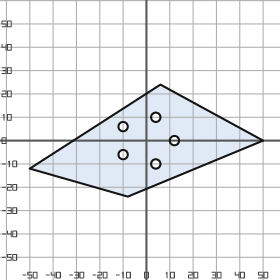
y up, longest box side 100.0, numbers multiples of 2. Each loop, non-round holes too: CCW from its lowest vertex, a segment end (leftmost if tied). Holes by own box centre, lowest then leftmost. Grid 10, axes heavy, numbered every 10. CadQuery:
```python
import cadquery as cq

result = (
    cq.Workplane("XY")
    .moveTo(-8.0, -24.0)
    .lineTo(50.0, 0.0)
    .lineTo(6.0, 24.0)
    .lineTo(-50.0, -12.0)
    .close()
    .moveTo(4.0, -10.0)
    .circle(2.0)
    .moveTo(-10.0, -6.0)
    .circle(2.0)
    .moveTo(12.0, 0.0)
    .circle(2.0)
    .moveTo(-10.0, 6.0)
    .circle(2.0)
    .moveTo(4.0, 10.0)
    .circle(2.0)
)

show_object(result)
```